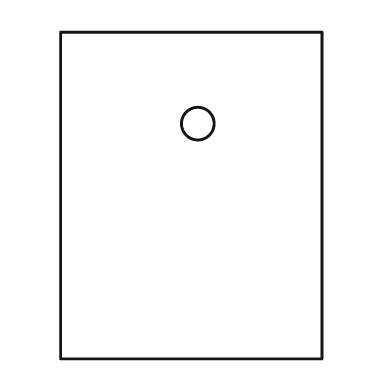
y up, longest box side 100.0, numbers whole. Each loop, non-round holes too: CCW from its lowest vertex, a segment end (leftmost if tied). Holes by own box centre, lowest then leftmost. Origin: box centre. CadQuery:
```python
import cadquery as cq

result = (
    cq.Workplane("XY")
    .moveTo(-40.0, -50.0)
    .lineTo(40.0, -50.0)
    .lineTo(40.0, 50.0)
    .lineTo(-40.0, 50.0)
    .close()
    .moveTo(2.0, 22.0)
    .circle(5.0)
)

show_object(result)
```